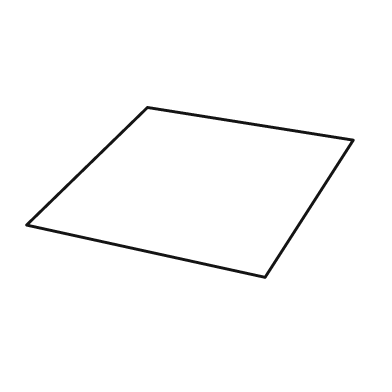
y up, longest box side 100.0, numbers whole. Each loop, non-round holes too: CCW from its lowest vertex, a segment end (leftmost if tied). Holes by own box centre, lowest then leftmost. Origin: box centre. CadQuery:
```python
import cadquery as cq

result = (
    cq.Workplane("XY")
    .moveTo(23.0, -26.0)
    .lineTo(50.0, 16.0)
    .lineTo(-13.0, 26.0)
    .lineTo(-50.0, -10.0)
    .close()
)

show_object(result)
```